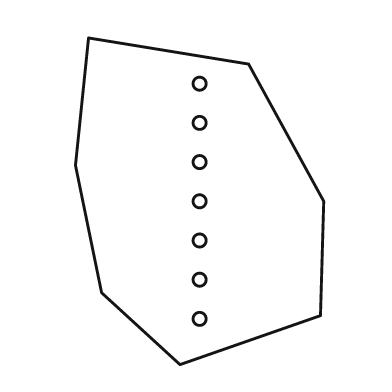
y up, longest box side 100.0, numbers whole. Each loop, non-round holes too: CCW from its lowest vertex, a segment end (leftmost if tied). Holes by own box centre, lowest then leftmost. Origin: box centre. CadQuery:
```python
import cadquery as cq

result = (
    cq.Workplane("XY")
    .moveTo(-6.0, -50.0)
    .lineTo(37.0, -35.0)
    .lineTo(38.0, 0.0)
    .lineTo(15.0, 42.0)
    .lineTo(-34.0, 50.0)
    .lineTo(-38.0, 11.0)
    .lineTo(-30.0, -28.0)
    .close()
    .moveTo(0.0, -36.0)
    .circle(2.0)
    .moveTo(0.0, -24.0)
    .circle(2.0)
    .moveTo(0.0, -12.0)
    .circle(2.0)
    .moveTo(0.0, 0.0)
    .circle(2.0)
    .moveTo(0.0, 12.0)
    .circle(2.0)
    .moveTo(0.0, 24.0)
    .circle(2.0)
    .moveTo(0.0, 36.0)
    .circle(2.0)
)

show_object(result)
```